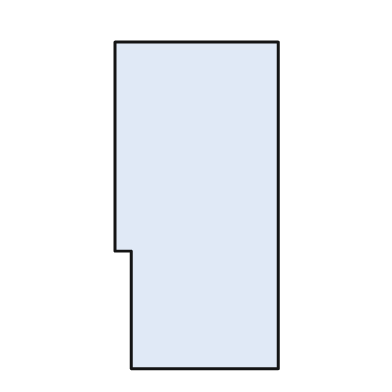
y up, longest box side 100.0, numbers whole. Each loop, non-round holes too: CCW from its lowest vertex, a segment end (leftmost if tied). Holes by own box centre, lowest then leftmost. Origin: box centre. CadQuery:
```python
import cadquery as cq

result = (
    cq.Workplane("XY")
    .moveTo(-20.0, -50.0)
    .lineTo(25.0, -50.0)
    .lineTo(25.0, 50.0)
    .lineTo(-25.0, 50.0)
    .lineTo(-25.0, -14.0)
    .lineTo(-20.0, -14.0)
    .close()
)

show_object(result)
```